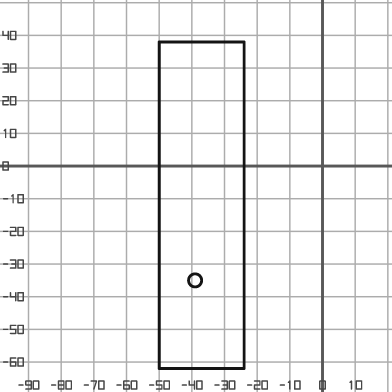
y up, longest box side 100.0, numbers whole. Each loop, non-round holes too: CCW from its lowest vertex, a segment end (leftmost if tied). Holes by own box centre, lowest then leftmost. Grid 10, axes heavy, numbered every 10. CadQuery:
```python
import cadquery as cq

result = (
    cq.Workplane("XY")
    .moveTo(-50.0, -62.0)
    .lineTo(-24.0, -62.0)
    .lineTo(-24.0, 38.0)
    .lineTo(-50.0, 38.0)
    .close()
    .moveTo(-39.0, -35.0)
    .circle(2.0)
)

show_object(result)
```